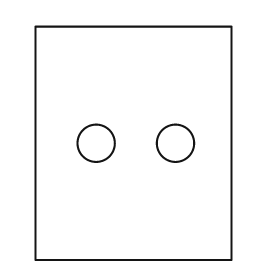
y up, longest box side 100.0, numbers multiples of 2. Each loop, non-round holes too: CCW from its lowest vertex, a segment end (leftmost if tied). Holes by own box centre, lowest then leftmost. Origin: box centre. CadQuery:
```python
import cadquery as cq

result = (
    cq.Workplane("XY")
    .moveTo(-42.0, -50.0)
    .lineTo(42.0, -50.0)
    .lineTo(42.0, 50.0)
    .lineTo(-42.0, 50.0)
    .close()
    .moveTo(-16.0, 0.0)
    .circle(8.0)
    .moveTo(18.0, 0.0)
    .circle(8.0)
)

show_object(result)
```